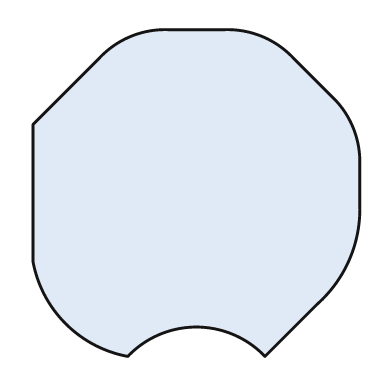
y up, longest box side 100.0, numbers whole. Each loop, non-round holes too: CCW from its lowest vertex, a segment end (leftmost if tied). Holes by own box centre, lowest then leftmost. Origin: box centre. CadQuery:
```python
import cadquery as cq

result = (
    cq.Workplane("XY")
    .moveTo(-21.0, -50.0)
    .threePointArc((0.0, -41.0), (21.0, -50.0))
    .lineTo(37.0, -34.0)
    .threePointArc((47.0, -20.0), (50.0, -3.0))
    .lineTo(50.0, 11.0)
    .threePointArc((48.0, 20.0), (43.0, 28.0))
    .lineTo(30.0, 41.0)
    .threePointArc((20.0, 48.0), (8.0, 50.0))
    .lineTo(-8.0, 50.0)
    .threePointArc((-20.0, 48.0), (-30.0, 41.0))
    .lineTo(-50.0, 21.0)
    .lineTo(-50.0, -21.0)
    .threePointArc((-40.0, -40.0), (-21.0, -50.0))
    .close()
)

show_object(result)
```